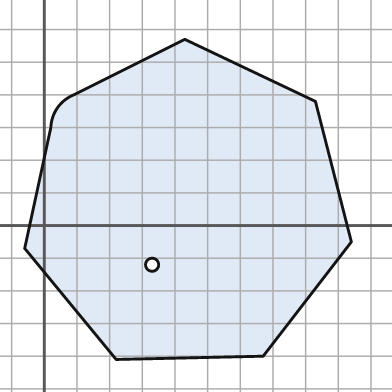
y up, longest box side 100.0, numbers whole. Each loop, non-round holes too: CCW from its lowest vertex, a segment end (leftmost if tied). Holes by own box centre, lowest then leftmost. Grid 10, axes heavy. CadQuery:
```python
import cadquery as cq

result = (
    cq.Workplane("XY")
    .moveTo(22.0, -41.0)
    .lineTo(67.0, -40.0)
    .lineTo(94.0, -5.0)
    .lineTo(83.0, 38.0)
    .lineTo(43.0, 57.0)
    .lineTo(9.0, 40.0)
    .threePointArc((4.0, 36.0), (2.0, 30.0))
    .lineTo(-6.0, -7.0)
    .close()
    .moveTo(33.0, -12.0)
    .circle(2.0)
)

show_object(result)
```